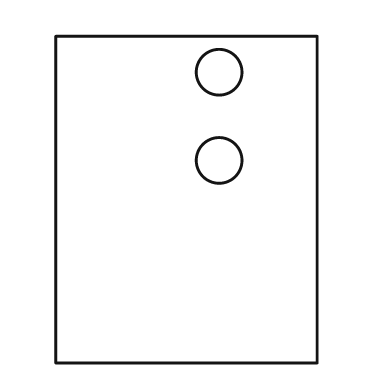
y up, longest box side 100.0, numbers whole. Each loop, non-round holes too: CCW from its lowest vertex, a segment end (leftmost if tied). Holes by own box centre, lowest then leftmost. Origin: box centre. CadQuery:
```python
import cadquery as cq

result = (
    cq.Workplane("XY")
    .moveTo(-40.0, -50.0)
    .lineTo(40.0, -50.0)
    .lineTo(40.0, 50.0)
    .lineTo(-40.0, 50.0)
    .close()
    .moveTo(10.0, 12.0)
    .circle(7.0)
    .moveTo(10.0, 39.0)
    .circle(7.0)
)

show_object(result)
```